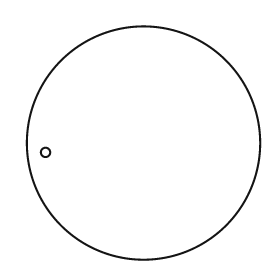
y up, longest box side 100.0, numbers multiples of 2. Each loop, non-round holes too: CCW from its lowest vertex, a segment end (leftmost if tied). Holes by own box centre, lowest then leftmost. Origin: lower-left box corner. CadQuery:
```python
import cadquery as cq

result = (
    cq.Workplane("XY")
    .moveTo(50.0, 50.0)
    .circle(50.0)
    .moveTo(8.0, 46.0)
    .circle(2.0)
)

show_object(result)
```